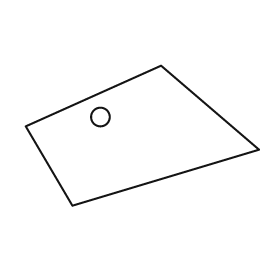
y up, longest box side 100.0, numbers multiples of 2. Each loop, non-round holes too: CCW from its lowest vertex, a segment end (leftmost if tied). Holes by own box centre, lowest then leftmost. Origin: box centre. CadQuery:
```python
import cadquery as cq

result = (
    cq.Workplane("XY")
    .moveTo(-30.0, -30.0)
    .lineTo(50.0, -6.0)
    .lineTo(8.0, 30.0)
    .lineTo(-50.0, 4.0)
    .close()
    .moveTo(-18.0, 8.0)
    .circle(4.0)
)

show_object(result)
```